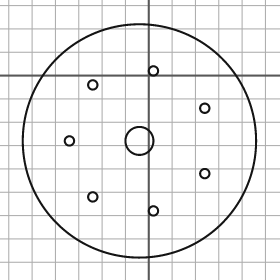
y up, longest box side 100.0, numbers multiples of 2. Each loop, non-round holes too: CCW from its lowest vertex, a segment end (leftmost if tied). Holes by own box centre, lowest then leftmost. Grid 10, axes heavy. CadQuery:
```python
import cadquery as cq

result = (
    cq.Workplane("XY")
    .moveTo(-4.0, -28.0)
    .circle(50.0)
    .moveTo(2.0, -58.0)
    .circle(2.0)
    .moveTo(-24.0, -52.0)
    .circle(2.0)
    .moveTo(24.0, -42.0)
    .circle(2.0)
    .moveTo(-34.0, -28.0)
    .circle(2.0)
    .moveTo(-4.0, -28.0)
    .circle(6.0)
    .moveTo(24.0, -14.0)
    .circle(2.0)
    .moveTo(-24.0, -4.0)
    .circle(2.0)
    .moveTo(2.0, 2.0)
    .circle(2.0)
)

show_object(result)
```